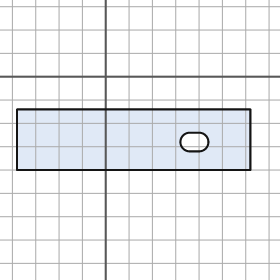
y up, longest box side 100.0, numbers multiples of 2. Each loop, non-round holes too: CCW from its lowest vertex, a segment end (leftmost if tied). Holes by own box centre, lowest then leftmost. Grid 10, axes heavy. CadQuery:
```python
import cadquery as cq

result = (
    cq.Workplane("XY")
    .moveTo(-38.0, -40.0)
    .lineTo(62.0, -40.0)
    .lineTo(62.0, -14.0)
    .lineTo(-38.0, -14.0)
    .close()
    .moveTo(36.0, -32.0)
    .lineTo(40.0, -32.0)
    .threePointArc((44.0, -28.0), (40.0, -24.0))
    .lineTo(36.0, -24.0)
    .threePointArc((32.0, -28.0), (36.0, -32.0))
    .close()
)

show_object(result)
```